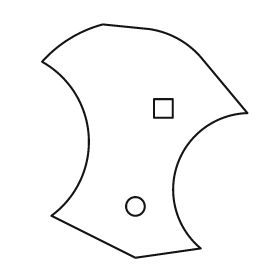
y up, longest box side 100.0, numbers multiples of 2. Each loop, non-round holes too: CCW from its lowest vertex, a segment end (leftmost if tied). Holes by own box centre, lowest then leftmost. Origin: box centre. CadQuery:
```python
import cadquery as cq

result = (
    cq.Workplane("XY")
    .moveTo(-4.0, -50.0)
    .lineTo(24.0, -46.0)
    .threePointArc((14.0, -10.0), (44.0, 12.0))
    .lineTo(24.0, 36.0)
    .threePointArc((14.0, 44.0), (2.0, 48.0))
    .lineTo(-18.0, 50.0)
    .threePointArc((-32.0, 44.0), (-44.0, 34.0))
    .threePointArc((-24.0, 2.0), (-40.0, -32.0))
    .close()
    .moveTo(-4.0, -28.0)
    .circle(4.0)
    .moveTo(4.0, 10.0)
    .lineTo(12.0, 10.0)
    .lineTo(12.0, 18.0)
    .lineTo(4.0, 18.0)
    .close()
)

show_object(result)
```